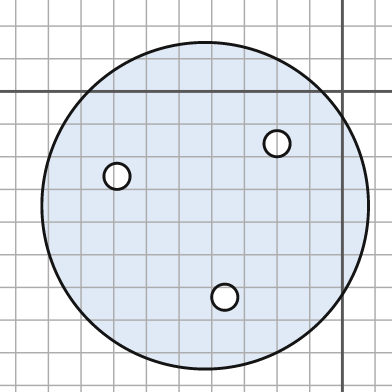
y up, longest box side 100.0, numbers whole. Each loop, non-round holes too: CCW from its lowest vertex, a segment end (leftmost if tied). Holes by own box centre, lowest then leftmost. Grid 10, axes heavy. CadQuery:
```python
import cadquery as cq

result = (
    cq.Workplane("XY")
    .moveTo(-42.0, -35.0)
    .circle(50.0)
    .moveTo(-36.0, -63.0)
    .circle(4.0)
    .moveTo(-69.0, -26.0)
    .circle(4.0)
    .moveTo(-20.0, -16.0)
    .circle(4.0)
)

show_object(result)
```